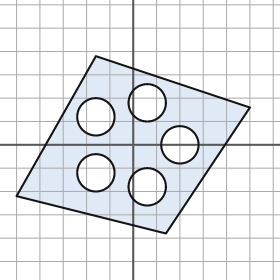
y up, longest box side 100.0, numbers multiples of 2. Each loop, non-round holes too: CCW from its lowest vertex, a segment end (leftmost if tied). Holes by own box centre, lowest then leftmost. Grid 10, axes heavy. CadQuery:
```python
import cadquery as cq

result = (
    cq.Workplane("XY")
    .moveTo(14.0, -38.0)
    .lineTo(50.0, 16.0)
    .lineTo(-16.0, 38.0)
    .lineTo(-50.0, -22.0)
    .close()
    .moveTo(6.0, -18.0)
    .circle(8.0)
    .moveTo(-16.0, -12.0)
    .circle(8.0)
    .moveTo(20.0, 0.0)
    .circle(8.0)
    .moveTo(-16.0, 12.0)
    .circle(8.0)
    .moveTo(6.0, 18.0)
    .circle(8.0)
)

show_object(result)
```